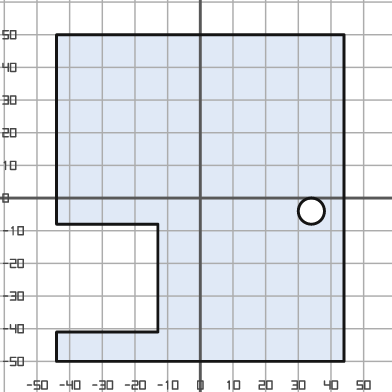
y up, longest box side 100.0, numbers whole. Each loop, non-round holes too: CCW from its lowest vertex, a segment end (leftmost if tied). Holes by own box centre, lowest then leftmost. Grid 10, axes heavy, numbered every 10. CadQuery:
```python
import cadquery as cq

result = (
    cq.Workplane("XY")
    .moveTo(-44.0, -50.0)
    .lineTo(44.0, -50.0)
    .lineTo(44.0, 50.0)
    .lineTo(-44.0, 50.0)
    .lineTo(-44.0, -8.0)
    .lineTo(-13.0, -8.0)
    .lineTo(-13.0, -41.0)
    .lineTo(-44.0, -41.0)
    .close()
    .moveTo(34.0, -4.0)
    .circle(4.0)
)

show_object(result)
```